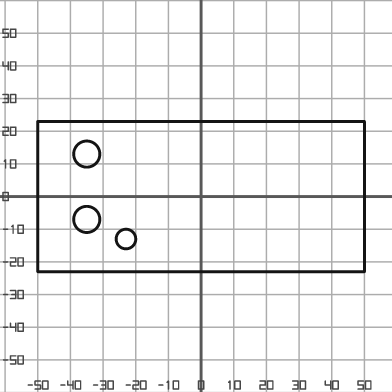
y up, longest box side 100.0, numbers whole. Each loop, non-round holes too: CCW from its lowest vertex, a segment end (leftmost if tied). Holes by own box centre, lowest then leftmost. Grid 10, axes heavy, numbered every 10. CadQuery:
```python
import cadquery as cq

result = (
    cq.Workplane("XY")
    .moveTo(-50.0, -23.0)
    .lineTo(50.0, -23.0)
    .lineTo(50.0, 23.0)
    .lineTo(-50.0, 23.0)
    .close()
    .moveTo(-23.0, -13.0)
    .circle(3.0)
    .moveTo(-35.0, -7.0)
    .circle(4.0)
    .moveTo(-35.0, 13.0)
    .circle(4.0)
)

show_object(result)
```